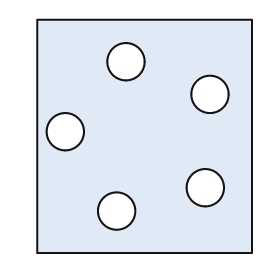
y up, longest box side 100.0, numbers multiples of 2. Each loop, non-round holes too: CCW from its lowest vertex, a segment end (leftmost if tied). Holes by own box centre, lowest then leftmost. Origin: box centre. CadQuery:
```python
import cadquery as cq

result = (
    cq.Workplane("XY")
    .moveTo(-46.0, -50.0)
    .lineTo(46.0, -50.0)
    .lineTo(46.0, 50.0)
    .lineTo(-46.0, 50.0)
    .close()
    .moveTo(-12.0, -32.0)
    .circle(8.0)
    .moveTo(26.0, -22.0)
    .circle(8.0)
    .moveTo(-34.0, 2.0)
    .circle(8.0)
    .moveTo(28.0, 18.0)
    .circle(8.0)
    .moveTo(-8.0, 32.0)
    .circle(8.0)
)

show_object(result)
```